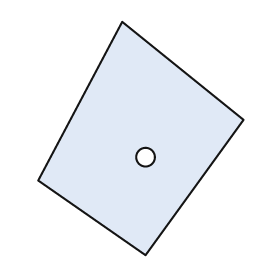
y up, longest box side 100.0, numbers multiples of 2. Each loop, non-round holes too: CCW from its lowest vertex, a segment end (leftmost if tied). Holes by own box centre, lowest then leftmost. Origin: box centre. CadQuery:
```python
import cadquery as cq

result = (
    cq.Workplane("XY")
    .moveTo(2.0, -50.0)
    .lineTo(44.0, 8.0)
    .lineTo(-8.0, 50.0)
    .lineTo(-44.0, -18.0)
    .close()
    .moveTo(2.0, -8.0)
    .circle(4.0)
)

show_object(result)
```